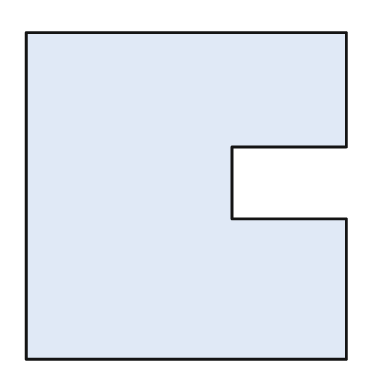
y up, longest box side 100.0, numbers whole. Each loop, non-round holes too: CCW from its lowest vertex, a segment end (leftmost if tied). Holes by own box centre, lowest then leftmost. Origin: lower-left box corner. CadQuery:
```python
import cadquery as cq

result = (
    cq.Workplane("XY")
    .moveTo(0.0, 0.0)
    .lineTo(98.0, 0.0)
    .lineTo(98.0, 43.0)
    .lineTo(63.0, 43.0)
    .lineTo(63.0, 65.0)
    .lineTo(98.0, 65.0)
    .lineTo(98.0, 100.0)
    .lineTo(0.0, 100.0)
    .close()
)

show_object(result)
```